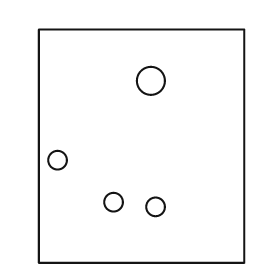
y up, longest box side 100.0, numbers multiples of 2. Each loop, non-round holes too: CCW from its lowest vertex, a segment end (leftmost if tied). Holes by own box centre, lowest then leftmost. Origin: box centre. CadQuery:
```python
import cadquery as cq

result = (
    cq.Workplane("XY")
    .moveTo(-44.0, -50.0)
    .lineTo(44.0, -50.0)
    .lineTo(44.0, 50.0)
    .lineTo(-44.0, 50.0)
    .close()
    .moveTo(6.0, -26.0)
    .circle(4.0)
    .moveTo(-12.0, -24.0)
    .circle(4.0)
    .moveTo(-36.0, -6.0)
    .circle(4.0)
    .moveTo(4.0, 28.0)
    .circle(6.0)
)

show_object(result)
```